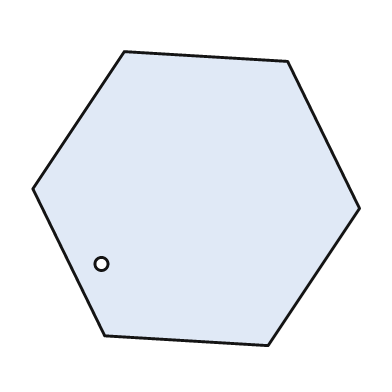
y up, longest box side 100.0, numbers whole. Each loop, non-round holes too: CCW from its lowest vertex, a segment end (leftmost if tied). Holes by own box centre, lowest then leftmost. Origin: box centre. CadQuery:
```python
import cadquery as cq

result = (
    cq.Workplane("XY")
    .moveTo(22.0, -45.0)
    .lineTo(50.0, -3.0)
    .lineTo(28.0, 42.0)
    .lineTo(-22.0, 45.0)
    .lineTo(-50.0, 3.0)
    .lineTo(-28.0, -42.0)
    .close()
    .moveTo(-29.0, -20.0)
    .circle(2.0)
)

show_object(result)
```